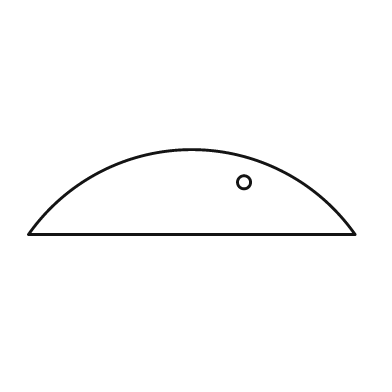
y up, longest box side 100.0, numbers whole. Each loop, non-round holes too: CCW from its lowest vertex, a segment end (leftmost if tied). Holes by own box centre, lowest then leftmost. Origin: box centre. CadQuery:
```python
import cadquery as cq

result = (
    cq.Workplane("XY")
    .moveTo(-50.0, -13.0)
    .lineTo(50.0, -13.0)
    .threePointArc((0.0, 13.0), (-50.0, -13.0))
    .close()
    .moveTo(16.0, 3.0)
    .circle(2.0)
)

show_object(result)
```